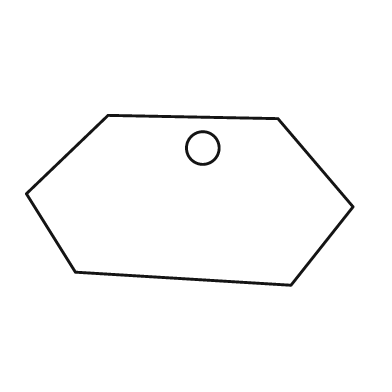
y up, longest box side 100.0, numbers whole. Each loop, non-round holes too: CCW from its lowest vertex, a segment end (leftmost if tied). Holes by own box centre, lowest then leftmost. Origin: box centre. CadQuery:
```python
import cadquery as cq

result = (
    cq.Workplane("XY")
    .moveTo(31.0, -26.0)
    .lineTo(50.0, -2.0)
    .lineTo(27.0, 25.0)
    .lineTo(-25.0, 26.0)
    .lineTo(-50.0, 2.0)
    .lineTo(-35.0, -22.0)
    .close()
    .moveTo(4.0, 16.0)
    .circle(5.0)
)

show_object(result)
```